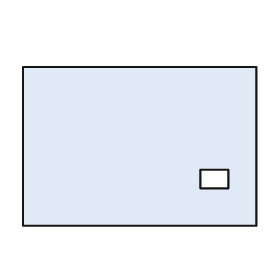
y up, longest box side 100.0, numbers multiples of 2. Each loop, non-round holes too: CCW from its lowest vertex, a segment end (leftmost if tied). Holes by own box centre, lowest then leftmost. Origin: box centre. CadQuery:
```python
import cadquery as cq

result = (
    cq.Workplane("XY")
    .moveTo(-50.0, -34.0)
    .lineTo(50.0, -34.0)
    .lineTo(50.0, 34.0)
    .lineTo(-50.0, 34.0)
    .close()
    .moveTo(26.0, -18.0)
    .lineTo(38.0, -18.0)
    .lineTo(38.0, -10.0)
    .lineTo(26.0, -10.0)
    .close()
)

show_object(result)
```